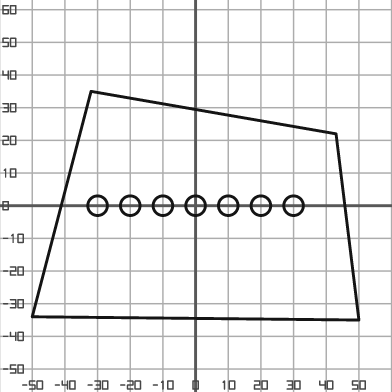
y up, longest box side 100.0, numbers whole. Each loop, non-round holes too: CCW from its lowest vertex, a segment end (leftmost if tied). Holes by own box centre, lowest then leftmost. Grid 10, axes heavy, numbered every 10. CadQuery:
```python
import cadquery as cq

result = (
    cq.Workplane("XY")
    .moveTo(50.0, -35.0)
    .lineTo(43.0, 22.0)
    .lineTo(-32.0, 35.0)
    .lineTo(-50.0, -34.0)
    .close()
    .moveTo(-30.0, 0.0)
    .circle(3.0)
    .moveTo(-20.0, 0.0)
    .circle(3.0)
    .moveTo(-10.0, 0.0)
    .circle(3.0)
    .moveTo(0.0, 0.0)
    .circle(3.0)
    .moveTo(10.0, 0.0)
    .circle(3.0)
    .moveTo(20.0, 0.0)
    .circle(3.0)
    .moveTo(30.0, 0.0)
    .circle(3.0)
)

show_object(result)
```